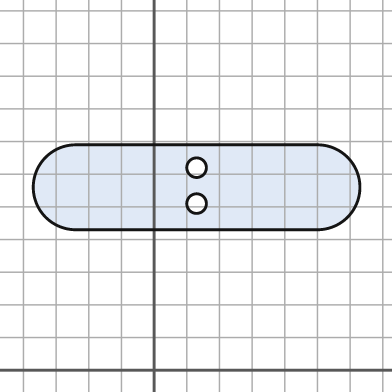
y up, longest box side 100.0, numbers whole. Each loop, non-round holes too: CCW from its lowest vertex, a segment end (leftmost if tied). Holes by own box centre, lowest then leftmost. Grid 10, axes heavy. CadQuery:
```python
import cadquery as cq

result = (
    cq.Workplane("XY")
    .moveTo(-24.0, 43.0)
    .lineTo(50.0, 43.0)
    .threePointArc((63.0, 56.0), (50.0, 69.0))
    .lineTo(-24.0, 69.0)
    .threePointArc((-37.0, 56.0), (-24.0, 43.0))
    .close()
    .moveTo(13.0, 51.0)
    .circle(3.0)
    .moveTo(13.0, 62.0)
    .circle(3.0)
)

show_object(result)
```